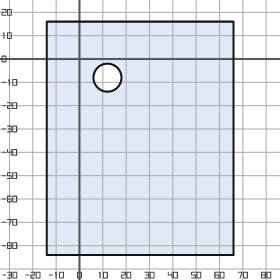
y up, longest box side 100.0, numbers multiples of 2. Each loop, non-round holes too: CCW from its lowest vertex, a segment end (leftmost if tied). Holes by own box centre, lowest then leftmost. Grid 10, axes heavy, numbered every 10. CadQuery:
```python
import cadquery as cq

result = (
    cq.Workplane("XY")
    .moveTo(-14.0, -84.0)
    .lineTo(66.0, -84.0)
    .lineTo(66.0, 16.0)
    .lineTo(-14.0, 16.0)
    .close()
    .moveTo(12.0, -8.0)
    .circle(6.0)
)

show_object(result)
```